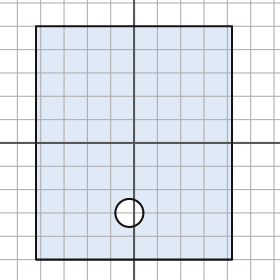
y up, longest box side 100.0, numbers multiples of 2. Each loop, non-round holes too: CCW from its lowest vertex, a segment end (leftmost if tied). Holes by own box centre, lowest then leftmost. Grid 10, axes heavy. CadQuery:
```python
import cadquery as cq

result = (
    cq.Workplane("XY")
    .moveTo(-42.0, -50.0)
    .lineTo(42.0, -50.0)
    .lineTo(42.0, 50.0)
    .lineTo(-42.0, 50.0)
    .close()
    .moveTo(-2.0, -30.0)
    .circle(6.0)
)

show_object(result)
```